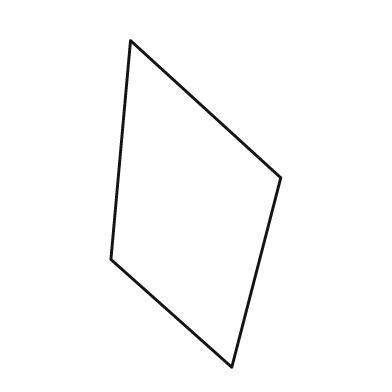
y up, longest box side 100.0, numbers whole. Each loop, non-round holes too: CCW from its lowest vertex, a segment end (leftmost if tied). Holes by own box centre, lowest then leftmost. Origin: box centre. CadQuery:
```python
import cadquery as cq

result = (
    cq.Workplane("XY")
    .moveTo(11.0, -50.0)
    .lineTo(26.0, 8.0)
    .lineTo(-20.0, 50.0)
    .lineTo(-26.0, -17.0)
    .close()
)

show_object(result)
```